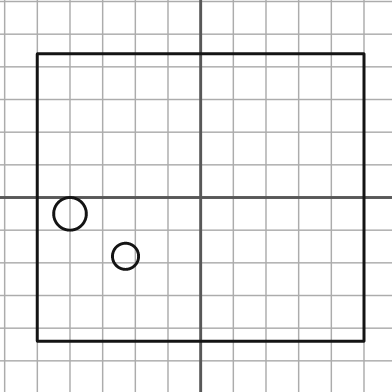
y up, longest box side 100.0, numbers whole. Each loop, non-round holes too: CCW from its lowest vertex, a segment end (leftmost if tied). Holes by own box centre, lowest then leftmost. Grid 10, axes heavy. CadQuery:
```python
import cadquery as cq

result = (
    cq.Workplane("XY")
    .moveTo(-50.0, -44.0)
    .lineTo(50.0, -44.0)
    .lineTo(50.0, 44.0)
    .lineTo(-50.0, 44.0)
    .close()
    .moveTo(-23.0, -18.0)
    .circle(4.0)
    .moveTo(-40.0, -5.0)
    .circle(5.0)
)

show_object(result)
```